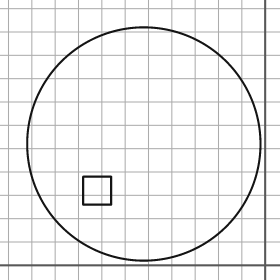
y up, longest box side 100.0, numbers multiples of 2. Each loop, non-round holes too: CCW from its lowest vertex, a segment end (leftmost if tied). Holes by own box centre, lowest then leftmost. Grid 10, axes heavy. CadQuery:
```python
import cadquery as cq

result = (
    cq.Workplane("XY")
    .moveTo(-52.0, 52.0)
    .circle(50.0)
    .moveTo(-78.0, 26.0)
    .lineTo(-66.0, 26.0)
    .lineTo(-66.0, 38.0)
    .lineTo(-78.0, 38.0)
    .close()
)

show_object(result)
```